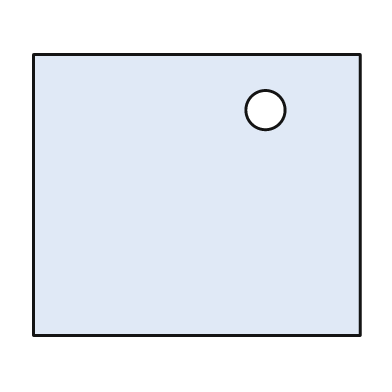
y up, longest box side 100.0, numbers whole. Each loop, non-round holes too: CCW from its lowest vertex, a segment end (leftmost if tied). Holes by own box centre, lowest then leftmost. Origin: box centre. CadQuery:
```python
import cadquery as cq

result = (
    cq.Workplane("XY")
    .moveTo(-50.0, -43.0)
    .lineTo(50.0, -43.0)
    .lineTo(50.0, 43.0)
    .lineTo(-50.0, 43.0)
    .close()
    .moveTo(21.0, 26.0)
    .circle(6.0)
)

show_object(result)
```